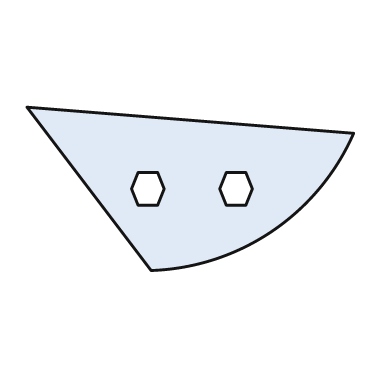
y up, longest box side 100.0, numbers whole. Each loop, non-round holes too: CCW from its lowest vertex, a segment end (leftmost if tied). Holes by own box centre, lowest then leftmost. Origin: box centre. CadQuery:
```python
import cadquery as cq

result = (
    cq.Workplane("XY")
    .moveTo(-12.0, -25.0)
    .threePointArc((25.0, -13.0), (50.0, 17.0))
    .lineTo(-50.0, 25.0)
    .close()
    .moveTo(-16.0, -5.0)
    .lineTo(-10.0, -5.0)
    .lineTo(-8.0, 0.0)
    .lineTo(-10.0, 5.0)
    .lineTo(-16.0, 5.0)
    .lineTo(-18.0, 0.0)
    .close()
    .moveTo(11.0, -5.0)
    .lineTo(17.0, -5.0)
    .lineTo(19.0, 0.0)
    .lineTo(17.0, 5.0)
    .lineTo(11.0, 5.0)
    .lineTo(9.0, 0.0)
    .close()
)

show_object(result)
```